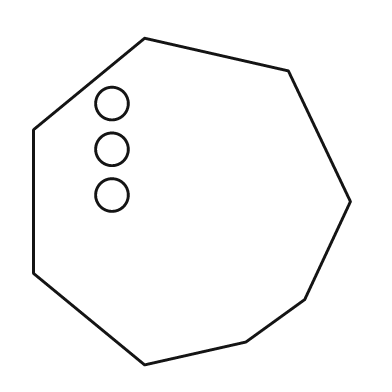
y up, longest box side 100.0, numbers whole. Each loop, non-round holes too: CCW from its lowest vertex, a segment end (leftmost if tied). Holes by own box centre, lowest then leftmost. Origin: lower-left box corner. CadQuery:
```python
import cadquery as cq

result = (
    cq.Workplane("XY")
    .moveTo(34.0, 0.0)
    .lineTo(65.0, 7.0)
    .lineTo(83.0, 20.0)
    .lineTo(97.0, 50.0)
    .lineTo(78.0, 90.0)
    .lineTo(34.0, 100.0)
    .lineTo(0.0, 72.0)
    .lineTo(0.0, 28.0)
    .close()
    .moveTo(24.0, 52.0)
    .circle(5.0)
    .moveTo(24.0, 66.0)
    .circle(5.0)
    .moveTo(24.0, 80.0)
    .circle(5.0)
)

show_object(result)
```